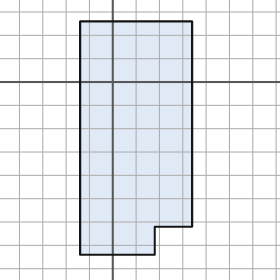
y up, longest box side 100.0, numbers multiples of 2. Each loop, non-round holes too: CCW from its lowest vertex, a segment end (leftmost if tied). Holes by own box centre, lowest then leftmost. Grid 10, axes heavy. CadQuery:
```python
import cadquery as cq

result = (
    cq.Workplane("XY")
    .moveTo(-14.0, -74.0)
    .lineTo(18.0, -74.0)
    .lineTo(18.0, -62.0)
    .lineTo(34.0, -62.0)
    .lineTo(34.0, 26.0)
    .lineTo(-14.0, 26.0)
    .close()
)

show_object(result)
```